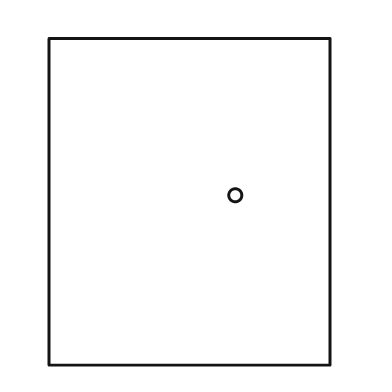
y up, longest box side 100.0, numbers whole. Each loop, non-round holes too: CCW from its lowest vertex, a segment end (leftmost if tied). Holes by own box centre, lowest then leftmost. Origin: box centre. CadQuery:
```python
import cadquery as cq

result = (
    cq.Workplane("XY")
    .moveTo(-43.0, -50.0)
    .lineTo(43.0, -50.0)
    .lineTo(43.0, 50.0)
    .lineTo(-43.0, 50.0)
    .close()
    .moveTo(14.0, 2.0)
    .circle(2.0)
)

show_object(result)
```